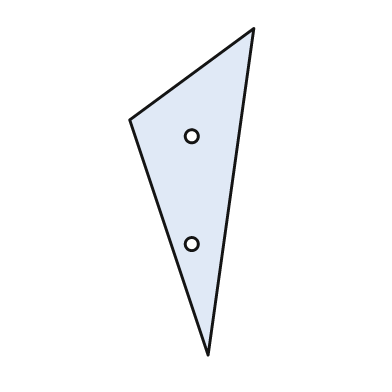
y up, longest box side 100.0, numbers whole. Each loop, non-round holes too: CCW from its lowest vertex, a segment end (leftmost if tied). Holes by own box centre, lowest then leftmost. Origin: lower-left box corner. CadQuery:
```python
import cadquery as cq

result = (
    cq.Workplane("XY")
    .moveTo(24.0, 0.0)
    .lineTo(38.0, 100.0)
    .lineTo(0.0, 72.0)
    .close()
    .moveTo(19.0, 34.0)
    .circle(2.0)
    .moveTo(19.0, 67.0)
    .circle(2.0)
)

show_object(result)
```